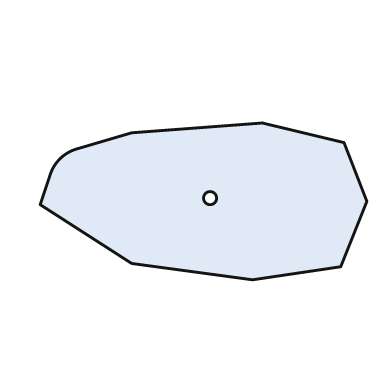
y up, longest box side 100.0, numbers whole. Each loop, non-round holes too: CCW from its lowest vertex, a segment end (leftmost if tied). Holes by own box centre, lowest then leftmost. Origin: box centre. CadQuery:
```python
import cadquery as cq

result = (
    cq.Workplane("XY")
    .moveTo(15.0, -24.0)
    .lineTo(42.0, -20.0)
    .lineTo(50.0, 0.0)
    .lineTo(43.0, 18.0)
    .lineTo(18.0, 24.0)
    .lineTo(-22.0, 21.0)
    .lineTo(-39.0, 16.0)
    .threePointArc((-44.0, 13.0), (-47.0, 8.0))
    .lineTo(-50.0, -1.0)
    .lineTo(-22.0, -19.0)
    .close()
    .moveTo(2.0, 1.0)
    .circle(2.0)
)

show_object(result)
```